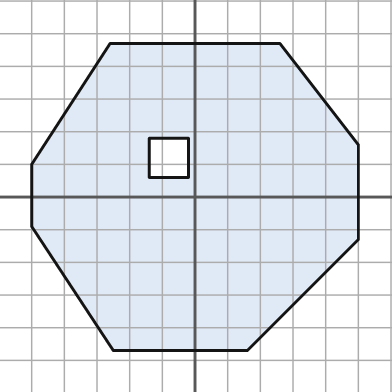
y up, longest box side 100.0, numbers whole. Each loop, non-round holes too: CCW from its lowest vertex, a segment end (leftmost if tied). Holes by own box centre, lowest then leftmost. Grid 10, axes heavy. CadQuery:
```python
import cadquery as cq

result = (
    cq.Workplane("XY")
    .moveTo(-25.0, -47.0)
    .lineTo(16.0, -47.0)
    .lineTo(50.0, -13.0)
    .lineTo(50.0, 16.0)
    .lineTo(26.0, 47.0)
    .lineTo(-26.0, 47.0)
    .lineTo(-50.0, 10.0)
    .lineTo(-50.0, -9.0)
    .close()
    .moveTo(-14.0, 6.0)
    .lineTo(-2.0, 6.0)
    .lineTo(-2.0, 18.0)
    .lineTo(-14.0, 18.0)
    .close()
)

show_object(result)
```